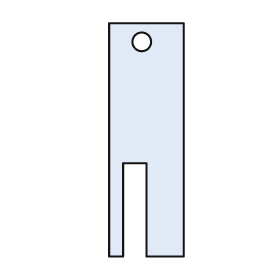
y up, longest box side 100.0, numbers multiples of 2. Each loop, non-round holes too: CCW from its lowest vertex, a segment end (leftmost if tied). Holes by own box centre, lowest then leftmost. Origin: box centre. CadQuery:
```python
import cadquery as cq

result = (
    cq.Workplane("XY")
    .moveTo(-16.0, -50.0)
    .lineTo(-10.0, -50.0)
    .lineTo(-10.0, -10.0)
    .lineTo(0.0, -10.0)
    .lineTo(0.0, -50.0)
    .lineTo(16.0, -50.0)
    .lineTo(16.0, 50.0)
    .lineTo(-16.0, 50.0)
    .close()
    .moveTo(-2.0, 42.0)
    .circle(4.0)
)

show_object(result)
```